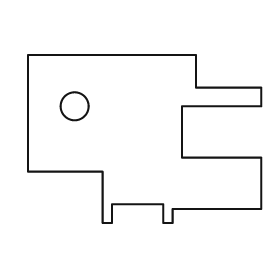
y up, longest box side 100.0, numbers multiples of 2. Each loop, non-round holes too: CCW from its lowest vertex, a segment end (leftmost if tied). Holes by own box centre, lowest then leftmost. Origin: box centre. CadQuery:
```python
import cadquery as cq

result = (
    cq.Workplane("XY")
    .moveTo(-18.0, -36.0)
    .lineTo(-14.0, -36.0)
    .lineTo(-14.0, -28.0)
    .lineTo(8.0, -28.0)
    .lineTo(8.0, -36.0)
    .lineTo(12.0, -36.0)
    .lineTo(12.0, -30.0)
    .lineTo(50.0, -30.0)
    .lineTo(50.0, -8.0)
    .lineTo(16.0, -8.0)
    .lineTo(16.0, 14.0)
    .lineTo(50.0, 14.0)
    .lineTo(50.0, 22.0)
    .lineTo(22.0, 22.0)
    .lineTo(22.0, 36.0)
    .lineTo(-50.0, 36.0)
    .lineTo(-50.0, -14.0)
    .lineTo(-18.0, -14.0)
    .close()
    .moveTo(-30.0, 14.0)
    .circle(6.0)
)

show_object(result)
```